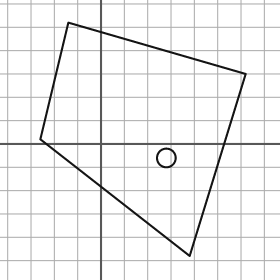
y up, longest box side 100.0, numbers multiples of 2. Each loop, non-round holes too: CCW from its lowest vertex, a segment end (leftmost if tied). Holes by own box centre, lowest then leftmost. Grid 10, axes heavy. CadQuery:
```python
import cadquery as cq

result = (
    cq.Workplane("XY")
    .moveTo(38.0, -48.0)
    .lineTo(62.0, 30.0)
    .lineTo(-14.0, 52.0)
    .lineTo(-26.0, 2.0)
    .close()
    .moveTo(28.0, -6.0)
    .circle(4.0)
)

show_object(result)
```